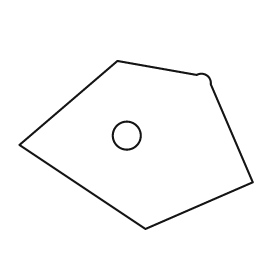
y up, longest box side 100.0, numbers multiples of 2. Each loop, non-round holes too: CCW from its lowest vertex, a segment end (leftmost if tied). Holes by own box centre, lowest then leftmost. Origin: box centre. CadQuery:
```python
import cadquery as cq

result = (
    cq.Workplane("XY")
    .moveTo(4.0, -36.0)
    .lineTo(50.0, -16.0)
    .lineTo(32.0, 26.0)
    .threePointArc((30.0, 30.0), (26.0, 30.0))
    .lineTo(-8.0, 36.0)
    .lineTo(-50.0, 0.0)
    .close()
    .moveTo(-4.0, 4.0)
    .circle(6.0)
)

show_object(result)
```